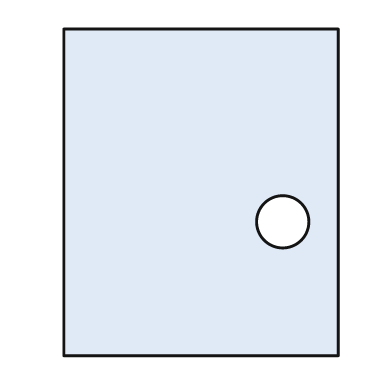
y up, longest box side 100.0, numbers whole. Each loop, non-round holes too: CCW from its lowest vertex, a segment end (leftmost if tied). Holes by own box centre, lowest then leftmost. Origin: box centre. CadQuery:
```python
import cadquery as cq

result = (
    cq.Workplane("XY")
    .moveTo(-42.0, -50.0)
    .lineTo(42.0, -50.0)
    .lineTo(42.0, 50.0)
    .lineTo(-42.0, 50.0)
    .close()
    .moveTo(25.0, -9.0)
    .circle(8.0)
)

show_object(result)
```